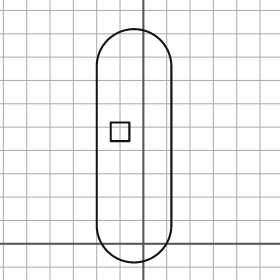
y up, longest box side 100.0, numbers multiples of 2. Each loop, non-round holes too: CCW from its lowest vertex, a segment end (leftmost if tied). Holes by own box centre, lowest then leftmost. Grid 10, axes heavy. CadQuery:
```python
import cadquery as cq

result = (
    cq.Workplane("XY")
    .moveTo(-20.0, 8.0)
    .threePointArc((-4.0, -8.0), (12.0, 8.0))
    .lineTo(12.0, 76.0)
    .threePointArc((-4.0, 92.0), (-20.0, 76.0))
    .close()
    .moveTo(-14.0, 44.0)
    .lineTo(-6.0, 44.0)
    .lineTo(-6.0, 52.0)
    .lineTo(-14.0, 52.0)
    .close()
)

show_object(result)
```